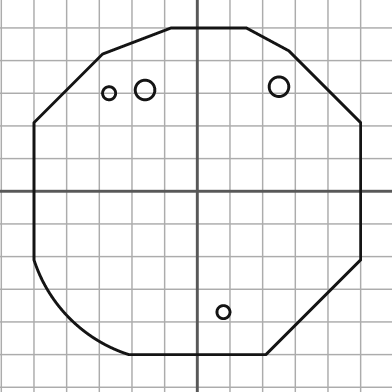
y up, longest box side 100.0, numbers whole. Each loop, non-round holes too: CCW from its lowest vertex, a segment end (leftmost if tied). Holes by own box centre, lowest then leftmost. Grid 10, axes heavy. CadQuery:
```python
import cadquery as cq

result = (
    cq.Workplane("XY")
    .moveTo(-21.0, -50.0)
    .lineTo(21.0, -50.0)
    .lineTo(50.0, -21.0)
    .lineTo(50.0, 21.0)
    .lineTo(28.0, 43.0)
    .lineTo(15.0, 50.0)
    .lineTo(-8.0, 50.0)
    .lineTo(-29.0, 42.0)
    .lineTo(-50.0, 21.0)
    .lineTo(-50.0, -21.0)
    .threePointArc((-39.0, -39.0), (-21.0, -50.0))
    .close()
    .moveTo(8.0, -37.0)
    .circle(2.0)
    .moveTo(-27.0, 30.0)
    .circle(2.0)
    .moveTo(-16.0, 31.0)
    .circle(3.0)
    .moveTo(25.0, 32.0)
    .circle(3.0)
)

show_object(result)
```